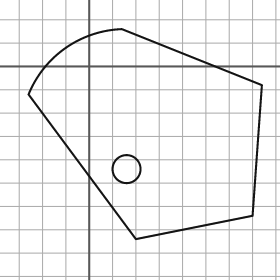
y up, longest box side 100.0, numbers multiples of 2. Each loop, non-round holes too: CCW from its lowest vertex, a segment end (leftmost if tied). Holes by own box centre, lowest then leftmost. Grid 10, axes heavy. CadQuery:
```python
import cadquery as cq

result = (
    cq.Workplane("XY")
    .moveTo(20.0, -74.0)
    .lineTo(70.0, -64.0)
    .lineTo(74.0, -8.0)
    .lineTo(14.0, 16.0)
    .threePointArc((-10.0, 8.0), (-26.0, -12.0))
    .close()
    .moveTo(16.0, -44.0)
    .circle(6.0)
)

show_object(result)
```